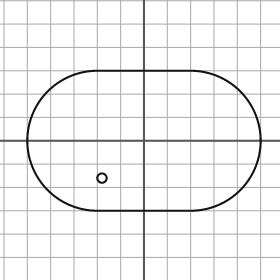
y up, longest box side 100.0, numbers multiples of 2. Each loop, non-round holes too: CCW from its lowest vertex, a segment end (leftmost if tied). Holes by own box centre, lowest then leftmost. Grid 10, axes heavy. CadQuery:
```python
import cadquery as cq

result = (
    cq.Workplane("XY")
    .moveTo(-20.0, -30.0)
    .lineTo(20.0, -30.0)
    .threePointArc((50.0, 0.0), (20.0, 30.0))
    .lineTo(-20.0, 30.0)
    .threePointArc((-50.0, 0.0), (-20.0, -30.0))
    .close()
    .moveTo(-18.0, -16.0)
    .circle(2.0)
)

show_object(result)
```